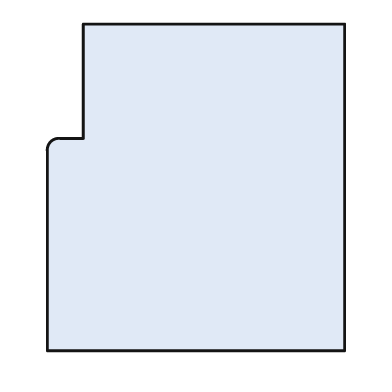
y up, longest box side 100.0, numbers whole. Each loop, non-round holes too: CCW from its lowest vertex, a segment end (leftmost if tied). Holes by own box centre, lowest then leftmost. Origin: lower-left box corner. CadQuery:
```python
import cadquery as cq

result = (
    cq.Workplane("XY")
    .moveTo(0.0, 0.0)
    .lineTo(91.0, 0.0)
    .lineTo(91.0, 100.0)
    .lineTo(11.0, 100.0)
    .lineTo(11.0, 65.0)
    .lineTo(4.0, 65.0)
    .threePointArc((1.0, 64.0), (0.0, 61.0))
    .close()
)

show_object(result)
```